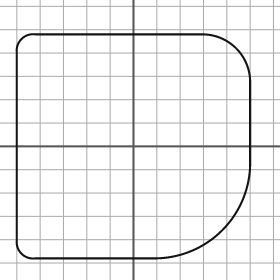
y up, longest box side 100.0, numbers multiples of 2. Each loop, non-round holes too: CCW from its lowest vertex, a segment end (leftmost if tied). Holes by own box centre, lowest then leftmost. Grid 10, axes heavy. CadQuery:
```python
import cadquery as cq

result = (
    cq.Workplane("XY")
    .moveTo(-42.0, -48.0)
    .lineTo(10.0, -48.0)
    .threePointArc((38.0, -36.0), (50.0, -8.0))
    .lineTo(50.0, 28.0)
    .threePointArc((44.0, 42.0), (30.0, 48.0))
    .lineTo(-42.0, 48.0)
    .threePointArc((-48.0, 46.0), (-50.0, 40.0))
    .lineTo(-50.0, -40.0)
    .threePointArc((-48.0, -46.0), (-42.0, -48.0))
    .close()
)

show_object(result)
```